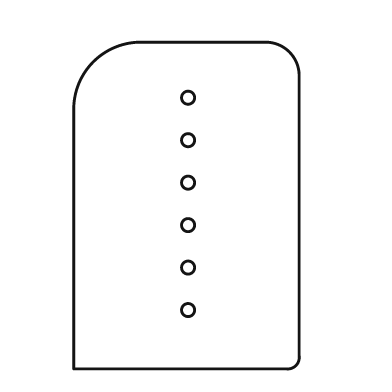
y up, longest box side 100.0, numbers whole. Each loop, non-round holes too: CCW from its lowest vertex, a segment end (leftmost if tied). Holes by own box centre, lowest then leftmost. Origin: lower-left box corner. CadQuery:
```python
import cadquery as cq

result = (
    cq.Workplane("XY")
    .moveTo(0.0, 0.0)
    .lineTo(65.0, 0.0)
    .threePointArc((68.0, 1.0), (69.0, 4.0))
    .lineTo(69.0, 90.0)
    .threePointArc((66.0, 97.0), (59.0, 100.0))
    .lineTo(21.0, 100.0)
    .threePointArc((6.0, 94.0), (0.0, 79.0))
    .close()
    .moveTo(35.0, 18.0)
    .circle(2.0)
    .moveTo(35.0, 31.0)
    .circle(2.0)
    .moveTo(35.0, 44.0)
    .circle(2.0)
    .moveTo(35.0, 57.0)
    .circle(2.0)
    .moveTo(35.0, 70.0)
    .circle(2.0)
    .moveTo(35.0, 83.0)
    .circle(2.0)
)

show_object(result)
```